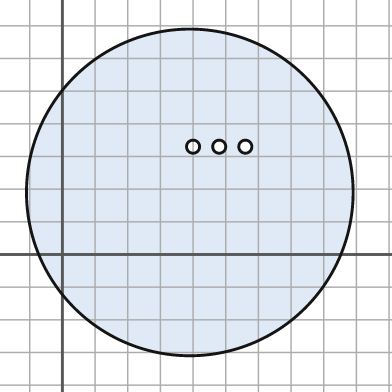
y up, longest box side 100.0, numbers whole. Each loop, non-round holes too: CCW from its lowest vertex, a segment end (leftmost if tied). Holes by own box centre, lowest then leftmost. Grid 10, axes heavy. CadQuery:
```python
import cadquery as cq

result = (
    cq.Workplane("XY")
    .moveTo(39.0, 19.0)
    .circle(50.0)
    .moveTo(40.0, 33.0)
    .circle(2.0)
    .moveTo(48.0, 33.0)
    .circle(2.0)
    .moveTo(56.0, 33.0)
    .circle(2.0)
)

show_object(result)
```